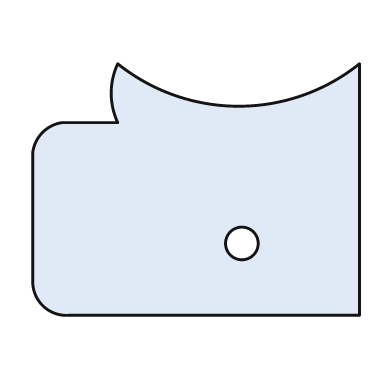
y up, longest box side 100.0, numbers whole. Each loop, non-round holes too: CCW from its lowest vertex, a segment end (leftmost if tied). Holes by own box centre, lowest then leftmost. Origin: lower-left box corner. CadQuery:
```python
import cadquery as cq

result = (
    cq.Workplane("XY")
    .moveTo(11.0, 0.0)
    .lineTo(100.0, 0.0)
    .lineTo(100.0, 77.0)
    .threePointArc((63.0, 64.0), (26.0, 77.0))
    .threePointArc((24.0, 68.0), (26.0, 59.0))
    .lineTo(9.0, 59.0)
    .threePointArc((3.0, 56.0), (0.0, 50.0))
    .lineTo(0.0, 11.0)
    .threePointArc((3.0, 3.0), (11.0, 0.0))
    .close()
    .moveTo(64.0, 22.0)
    .circle(5.0)
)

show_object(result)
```